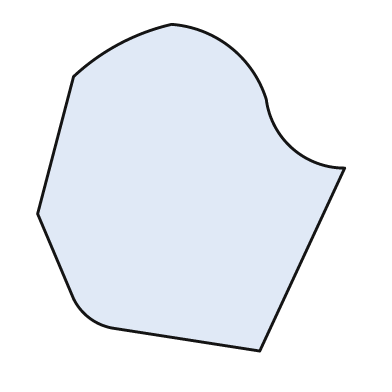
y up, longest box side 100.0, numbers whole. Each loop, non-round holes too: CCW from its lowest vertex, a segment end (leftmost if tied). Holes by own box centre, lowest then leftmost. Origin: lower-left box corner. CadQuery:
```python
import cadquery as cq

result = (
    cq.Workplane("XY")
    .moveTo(68.0, 0.0)
    .lineTo(94.0, 56.0)
    .threePointArc((78.0, 62.0), (70.0, 77.0))
    .threePointArc((59.0, 93.0), (41.0, 100.0))
    .threePointArc((25.0, 94.0), (11.0, 84.0))
    .lineTo(0.0, 42.0)
    .lineTo(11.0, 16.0)
    .threePointArc((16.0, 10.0), (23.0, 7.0))
    .close()
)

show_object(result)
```